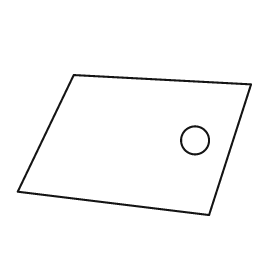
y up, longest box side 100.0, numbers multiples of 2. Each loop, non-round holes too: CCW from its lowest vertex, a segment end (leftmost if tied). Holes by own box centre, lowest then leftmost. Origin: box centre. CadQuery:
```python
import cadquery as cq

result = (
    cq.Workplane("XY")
    .moveTo(32.0, -30.0)
    .lineTo(50.0, 26.0)
    .lineTo(-26.0, 30.0)
    .lineTo(-50.0, -20.0)
    .close()
    .moveTo(26.0, 2.0)
    .circle(6.0)
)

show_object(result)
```